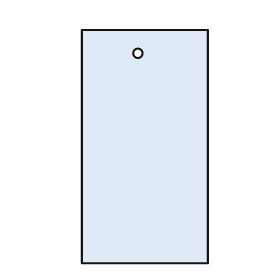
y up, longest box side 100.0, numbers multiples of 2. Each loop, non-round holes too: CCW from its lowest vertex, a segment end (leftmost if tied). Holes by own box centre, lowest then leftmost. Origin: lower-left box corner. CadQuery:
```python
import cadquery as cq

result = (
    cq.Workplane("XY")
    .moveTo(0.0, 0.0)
    .lineTo(54.0, 0.0)
    .lineTo(54.0, 100.0)
    .lineTo(0.0, 100.0)
    .close()
    .moveTo(24.0, 90.0)
    .circle(2.0)
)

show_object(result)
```